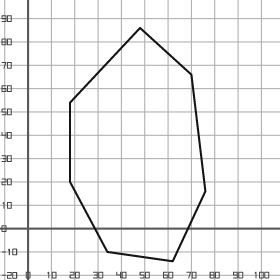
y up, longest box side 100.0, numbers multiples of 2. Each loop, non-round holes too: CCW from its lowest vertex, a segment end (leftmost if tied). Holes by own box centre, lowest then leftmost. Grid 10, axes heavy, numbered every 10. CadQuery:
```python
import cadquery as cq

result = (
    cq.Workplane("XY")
    .moveTo(62.0, -14.0)
    .lineTo(76.0, 16.0)
    .lineTo(70.0, 66.0)
    .lineTo(48.0, 86.0)
    .lineTo(18.0, 54.0)
    .lineTo(18.0, 20.0)
    .lineTo(34.0, -10.0)
    .close()
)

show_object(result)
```